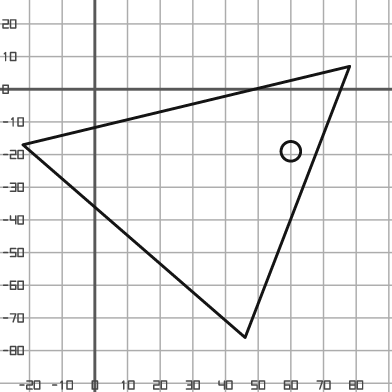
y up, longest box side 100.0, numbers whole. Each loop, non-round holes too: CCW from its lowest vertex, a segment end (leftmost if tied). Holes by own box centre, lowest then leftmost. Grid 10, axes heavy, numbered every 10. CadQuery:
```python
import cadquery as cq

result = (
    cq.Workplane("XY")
    .moveTo(46.0, -76.0)
    .lineTo(78.0, 7.0)
    .lineTo(-22.0, -17.0)
    .close()
    .moveTo(60.0, -19.0)
    .circle(3.0)
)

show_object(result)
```